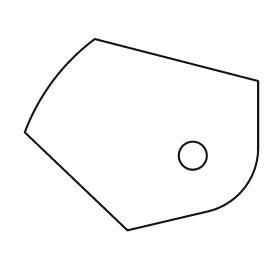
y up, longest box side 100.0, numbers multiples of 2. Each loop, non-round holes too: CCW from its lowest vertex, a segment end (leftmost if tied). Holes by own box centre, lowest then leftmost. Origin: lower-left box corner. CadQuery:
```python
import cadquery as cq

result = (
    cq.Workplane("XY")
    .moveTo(44.0, 0.0)
    .lineTo(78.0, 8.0)
    .threePointArc((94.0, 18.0), (100.0, 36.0))
    .lineTo(100.0, 64.0)
    .lineTo(30.0, 82.0)
    .threePointArc((12.0, 64.0), (0.0, 42.0))
    .close()
    .moveTo(72.0, 32.0)
    .circle(6.0)
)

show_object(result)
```